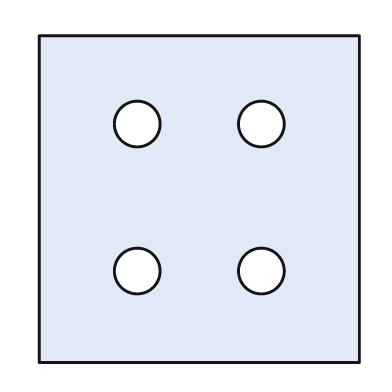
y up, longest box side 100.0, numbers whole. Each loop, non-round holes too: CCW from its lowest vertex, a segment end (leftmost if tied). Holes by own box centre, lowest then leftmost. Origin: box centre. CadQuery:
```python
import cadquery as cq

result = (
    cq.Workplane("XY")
    .moveTo(-49.0, -50.0)
    .lineTo(49.0, -50.0)
    .lineTo(49.0, 50.0)
    .lineTo(-49.0, 50.0)
    .close()
    .moveTo(-19.0, -22.0)
    .circle(7.0)
    .moveTo(19.0, -22.0)
    .circle(7.0)
    .moveTo(-19.0, 23.0)
    .circle(7.0)
    .moveTo(19.0, 23.0)
    .circle(7.0)
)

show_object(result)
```